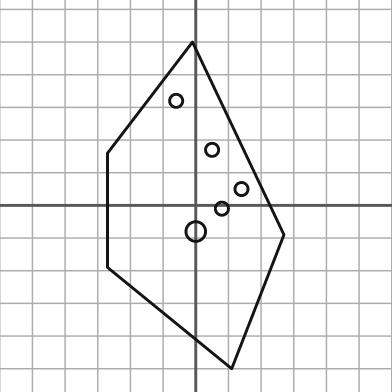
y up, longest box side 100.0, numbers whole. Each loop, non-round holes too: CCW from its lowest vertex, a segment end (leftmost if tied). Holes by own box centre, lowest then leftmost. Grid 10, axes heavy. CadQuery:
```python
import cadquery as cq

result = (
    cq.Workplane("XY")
    .moveTo(11.0, -50.0)
    .lineTo(27.0, -9.0)
    .lineTo(-1.0, 50.0)
    .lineTo(-27.0, 16.0)
    .lineTo(-27.0, -19.0)
    .close()
    .moveTo(0.0, -8.0)
    .circle(3.0)
    .moveTo(8.0, -1.0)
    .circle(2.0)
    .moveTo(14.0, 5.0)
    .circle(2.0)
    .moveTo(5.0, 17.0)
    .circle(2.0)
    .moveTo(-6.0, 32.0)
    .circle(2.0)
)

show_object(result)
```